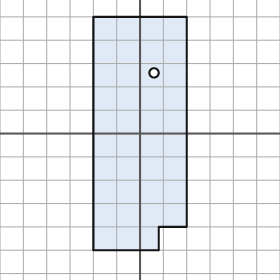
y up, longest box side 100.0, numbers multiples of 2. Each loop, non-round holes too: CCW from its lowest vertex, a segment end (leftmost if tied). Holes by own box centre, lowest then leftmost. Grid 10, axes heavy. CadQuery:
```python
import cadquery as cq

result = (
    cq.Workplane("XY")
    .moveTo(-20.0, -50.0)
    .lineTo(8.0, -50.0)
    .lineTo(8.0, -40.0)
    .lineTo(20.0, -40.0)
    .lineTo(20.0, 50.0)
    .lineTo(-20.0, 50.0)
    .close()
    .moveTo(6.0, 26.0)
    .circle(2.0)
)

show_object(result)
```